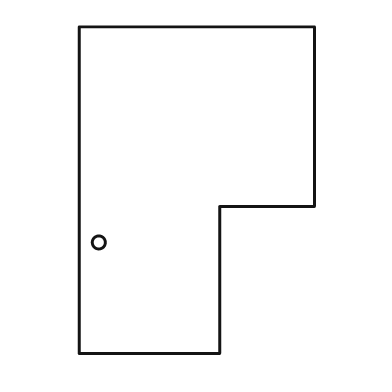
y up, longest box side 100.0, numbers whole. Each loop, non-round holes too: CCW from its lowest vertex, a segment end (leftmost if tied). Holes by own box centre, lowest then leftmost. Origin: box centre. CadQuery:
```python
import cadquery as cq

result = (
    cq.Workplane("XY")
    .moveTo(-36.0, -50.0)
    .lineTo(7.0, -50.0)
    .lineTo(7.0, -5.0)
    .lineTo(36.0, -5.0)
    .lineTo(36.0, 50.0)
    .lineTo(-36.0, 50.0)
    .close()
    .moveTo(-30.0, -16.0)
    .circle(2.0)
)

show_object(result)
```